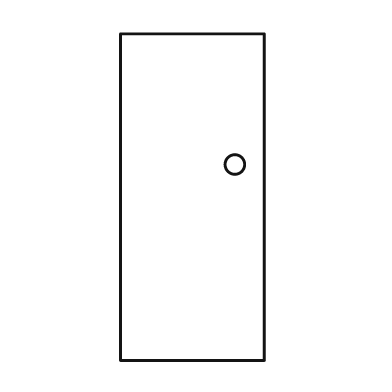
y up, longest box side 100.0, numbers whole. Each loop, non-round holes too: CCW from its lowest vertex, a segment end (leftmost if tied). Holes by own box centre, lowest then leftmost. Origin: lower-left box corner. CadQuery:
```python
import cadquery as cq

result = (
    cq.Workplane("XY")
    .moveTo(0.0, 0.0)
    .lineTo(44.0, 0.0)
    .lineTo(44.0, 100.0)
    .lineTo(0.0, 100.0)
    .close()
    .moveTo(35.0, 60.0)
    .circle(3.0)
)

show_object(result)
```